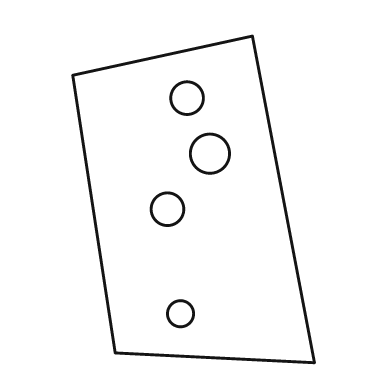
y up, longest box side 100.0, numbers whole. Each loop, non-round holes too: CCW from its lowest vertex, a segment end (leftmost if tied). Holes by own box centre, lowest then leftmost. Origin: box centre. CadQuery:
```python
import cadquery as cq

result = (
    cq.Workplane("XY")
    .moveTo(37.0, -50.0)
    .lineTo(18.0, 50.0)
    .lineTo(-37.0, 38.0)
    .lineTo(-24.0, -47.0)
    .close()
    .moveTo(-4.0, -35.0)
    .circle(4.0)
    .moveTo(-8.0, -3.0)
    .circle(5.0)
    .moveTo(5.0, 14.0)
    .circle(6.0)
    .moveTo(-2.0, 31.0)
    .circle(5.0)
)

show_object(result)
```